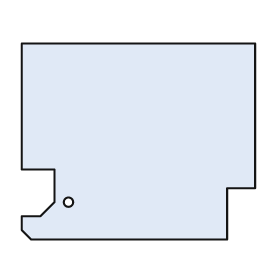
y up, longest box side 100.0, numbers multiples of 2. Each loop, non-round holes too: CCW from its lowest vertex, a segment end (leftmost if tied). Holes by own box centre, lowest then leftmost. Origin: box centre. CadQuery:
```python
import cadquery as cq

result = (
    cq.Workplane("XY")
    .moveTo(-46.0, -42.0)
    .lineTo(38.0, -42.0)
    .lineTo(38.0, -20.0)
    .lineTo(50.0, -20.0)
    .lineTo(50.0, 42.0)
    .lineTo(-50.0, 42.0)
    .lineTo(-50.0, -12.0)
    .lineTo(-36.0, -12.0)
    .lineTo(-36.0, -26.0)
    .lineTo(-42.0, -32.0)
    .lineTo(-50.0, -32.0)
    .lineTo(-50.0, -38.0)
    .close()
    .moveTo(-30.0, -26.0)
    .circle(2.0)
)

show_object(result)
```